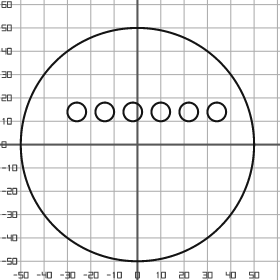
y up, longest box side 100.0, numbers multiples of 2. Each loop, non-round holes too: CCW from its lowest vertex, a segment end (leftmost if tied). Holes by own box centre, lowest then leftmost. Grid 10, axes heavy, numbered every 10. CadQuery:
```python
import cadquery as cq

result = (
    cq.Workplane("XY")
    .moveTo(0.0, 0.0)
    .circle(50.0)
    .moveTo(-26.0, 14.0)
    .circle(4.0)
    .moveTo(-14.0, 14.0)
    .circle(4.0)
    .moveTo(-2.0, 14.0)
    .circle(4.0)
    .moveTo(10.0, 14.0)
    .circle(4.0)
    .moveTo(22.0, 14.0)
    .circle(4.0)
    .moveTo(34.0, 14.0)
    .circle(4.0)
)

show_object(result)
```